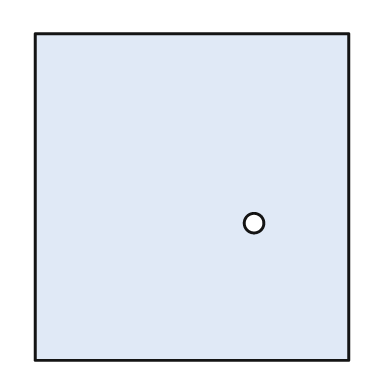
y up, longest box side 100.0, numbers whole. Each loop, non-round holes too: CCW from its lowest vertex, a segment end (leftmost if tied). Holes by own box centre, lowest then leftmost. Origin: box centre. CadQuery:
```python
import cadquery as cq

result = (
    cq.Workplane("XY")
    .moveTo(-48.0, -50.0)
    .lineTo(48.0, -50.0)
    .lineTo(48.0, 50.0)
    .lineTo(-48.0, 50.0)
    .close()
    .moveTo(19.0, -8.0)
    .circle(3.0)
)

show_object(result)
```